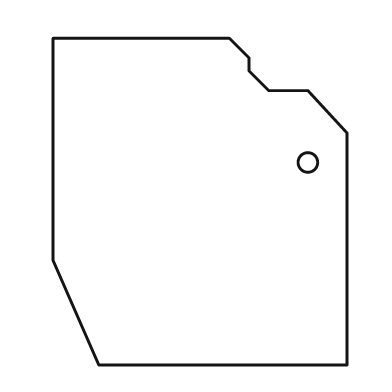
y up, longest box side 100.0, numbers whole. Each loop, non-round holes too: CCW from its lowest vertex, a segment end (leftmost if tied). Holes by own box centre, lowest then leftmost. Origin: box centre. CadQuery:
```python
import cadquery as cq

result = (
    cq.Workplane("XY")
    .moveTo(-31.0, -50.0)
    .lineTo(45.0, -50.0)
    .lineTo(45.0, 21.0)
    .lineTo(33.0, 34.0)
    .lineTo(21.0, 34.0)
    .lineTo(15.0, 40.0)
    .lineTo(15.0, 44.0)
    .lineTo(9.0, 50.0)
    .lineTo(-45.0, 50.0)
    .lineTo(-45.0, -18.0)
    .close()
    .moveTo(33.0, 12.0)
    .circle(3.0)
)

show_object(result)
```